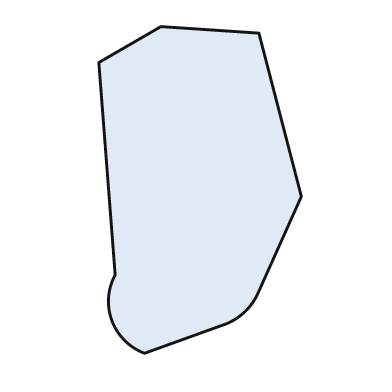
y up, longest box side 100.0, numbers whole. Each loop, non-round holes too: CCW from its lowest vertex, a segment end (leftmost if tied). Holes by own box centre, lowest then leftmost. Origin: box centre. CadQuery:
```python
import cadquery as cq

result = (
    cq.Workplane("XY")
    .moveTo(-17.0, -50.0)
    .lineTo(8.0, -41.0)
    .threePointArc((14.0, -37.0), (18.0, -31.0))
    .lineTo(31.0, -2.0)
    .lineTo(18.0, 48.0)
    .lineTo(-12.0, 50.0)
    .lineTo(-31.0, 39.0)
    .lineTo(-26.0, -26.0)
    .threePointArc((-27.0, -40.0), (-17.0, -50.0))
    .close()
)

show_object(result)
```